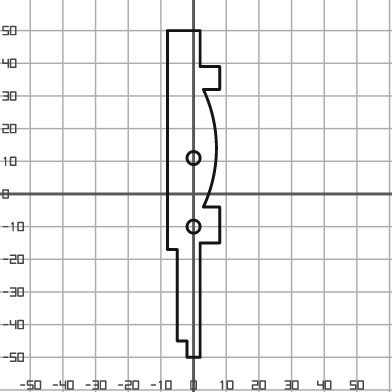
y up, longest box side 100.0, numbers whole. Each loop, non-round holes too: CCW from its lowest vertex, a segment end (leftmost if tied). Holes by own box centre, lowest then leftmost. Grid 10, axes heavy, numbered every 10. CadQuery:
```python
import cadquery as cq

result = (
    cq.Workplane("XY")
    .moveTo(-2.0, -50.0)
    .lineTo(2.0, -50.0)
    .lineTo(2.0, -15.0)
    .lineTo(8.0, -15.0)
    .lineTo(8.0, -4.0)
    .lineTo(3.0, -4.0)
    .threePointArc((7.0, 14.0), (3.0, 32.0))
    .lineTo(8.0, 32.0)
    .lineTo(8.0, 39.0)
    .lineTo(2.0, 39.0)
    .lineTo(2.0, 50.0)
    .lineTo(-8.0, 50.0)
    .lineTo(-8.0, -17.0)
    .lineTo(-5.0, -17.0)
    .lineTo(-5.0, -45.0)
    .lineTo(-2.0, -45.0)
    .close()
    .moveTo(0.0, -10.0)
    .circle(2.0)
    .moveTo(0.0, 11.0)
    .circle(2.0)
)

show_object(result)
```